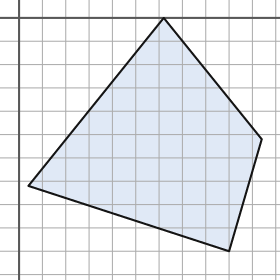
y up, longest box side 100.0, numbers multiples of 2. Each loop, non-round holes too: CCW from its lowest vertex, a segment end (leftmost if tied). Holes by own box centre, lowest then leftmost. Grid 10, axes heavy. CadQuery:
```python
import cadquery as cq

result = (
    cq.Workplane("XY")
    .moveTo(90.0, -100.0)
    .lineTo(104.0, -52.0)
    .lineTo(62.0, 0.0)
    .lineTo(4.0, -72.0)
    .close()
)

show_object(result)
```